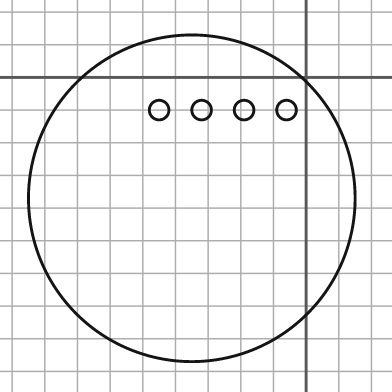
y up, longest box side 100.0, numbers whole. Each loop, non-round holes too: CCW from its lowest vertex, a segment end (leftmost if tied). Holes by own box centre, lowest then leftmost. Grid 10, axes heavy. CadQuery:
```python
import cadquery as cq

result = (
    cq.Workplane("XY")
    .moveTo(-35.0, -37.0)
    .circle(50.0)
    .moveTo(-45.0, -10.0)
    .circle(3.0)
    .moveTo(-32.0, -10.0)
    .circle(3.0)
    .moveTo(-19.0, -10.0)
    .circle(3.0)
    .moveTo(-6.0, -10.0)
    .circle(3.0)
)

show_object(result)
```